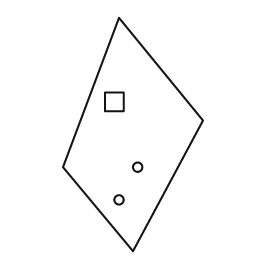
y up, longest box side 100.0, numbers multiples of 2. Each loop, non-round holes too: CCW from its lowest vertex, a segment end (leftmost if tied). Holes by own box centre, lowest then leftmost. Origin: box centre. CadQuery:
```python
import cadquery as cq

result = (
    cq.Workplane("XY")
    .moveTo(0.0, -50.0)
    .lineTo(30.0, 6.0)
    .lineTo(-6.0, 50.0)
    .lineTo(-30.0, -14.0)
    .close()
    .moveTo(-6.0, -28.0)
    .circle(2.0)
    .moveTo(2.0, -14.0)
    .circle(2.0)
    .moveTo(-12.0, 10.0)
    .lineTo(-4.0, 10.0)
    .lineTo(-4.0, 18.0)
    .lineTo(-12.0, 18.0)
    .close()
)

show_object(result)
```